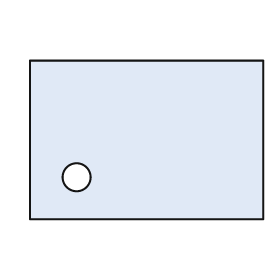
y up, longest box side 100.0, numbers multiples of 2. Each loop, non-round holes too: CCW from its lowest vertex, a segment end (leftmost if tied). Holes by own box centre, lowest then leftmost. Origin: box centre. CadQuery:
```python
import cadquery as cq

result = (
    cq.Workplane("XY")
    .moveTo(-50.0, -34.0)
    .lineTo(50.0, -34.0)
    .lineTo(50.0, 34.0)
    .lineTo(-50.0, 34.0)
    .close()
    .moveTo(-30.0, -16.0)
    .circle(6.0)
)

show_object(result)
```